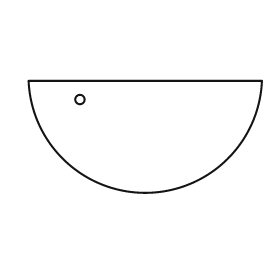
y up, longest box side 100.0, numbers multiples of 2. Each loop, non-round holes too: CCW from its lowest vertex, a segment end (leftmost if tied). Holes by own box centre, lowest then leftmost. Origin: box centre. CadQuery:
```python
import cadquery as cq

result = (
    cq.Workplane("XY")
    .moveTo(-50.0, 24.0)
    .threePointArc((0.0, -24.0), (50.0, 24.0))
    .close()
    .moveTo(-28.0, 16.0)
    .circle(2.0)
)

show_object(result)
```